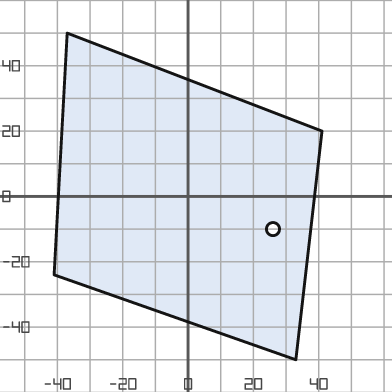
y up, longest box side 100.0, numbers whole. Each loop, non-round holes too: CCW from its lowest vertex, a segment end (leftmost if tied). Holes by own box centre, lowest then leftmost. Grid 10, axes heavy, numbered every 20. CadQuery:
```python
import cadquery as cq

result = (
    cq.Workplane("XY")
    .moveTo(33.0, -50.0)
    .lineTo(41.0, 20.0)
    .lineTo(-37.0, 50.0)
    .lineTo(-41.0, -24.0)
    .close()
    .moveTo(26.0, -10.0)
    .circle(2.0)
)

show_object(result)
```